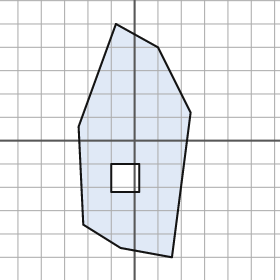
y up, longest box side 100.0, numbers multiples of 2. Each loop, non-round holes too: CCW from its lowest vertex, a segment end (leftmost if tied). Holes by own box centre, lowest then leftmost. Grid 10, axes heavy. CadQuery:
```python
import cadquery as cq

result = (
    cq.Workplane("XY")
    .moveTo(16.0, -50.0)
    .lineTo(24.0, 12.0)
    .lineTo(10.0, 40.0)
    .lineTo(-8.0, 50.0)
    .lineTo(-24.0, 6.0)
    .lineTo(-22.0, -36.0)
    .lineTo(-6.0, -46.0)
    .close()
    .moveTo(-10.0, -22.0)
    .lineTo(2.0, -22.0)
    .lineTo(2.0, -10.0)
    .lineTo(-10.0, -10.0)
    .close()
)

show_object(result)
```